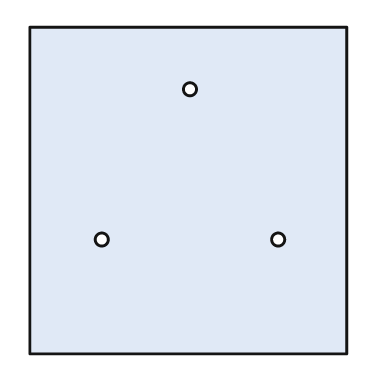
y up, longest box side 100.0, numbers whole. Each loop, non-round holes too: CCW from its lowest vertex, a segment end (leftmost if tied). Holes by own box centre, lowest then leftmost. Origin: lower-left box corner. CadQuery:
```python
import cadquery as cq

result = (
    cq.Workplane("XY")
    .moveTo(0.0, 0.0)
    .lineTo(97.0, 0.0)
    .lineTo(97.0, 100.0)
    .lineTo(0.0, 100.0)
    .close()
    .moveTo(22.0, 35.0)
    .circle(2.0)
    .moveTo(76.0, 35.0)
    .circle(2.0)
    .moveTo(49.0, 81.0)
    .circle(2.0)
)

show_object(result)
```